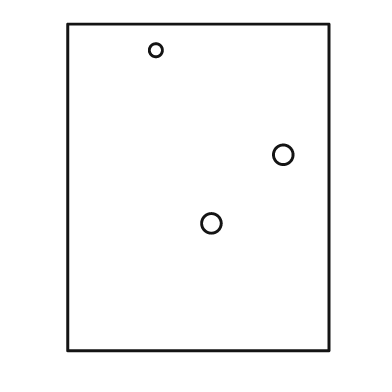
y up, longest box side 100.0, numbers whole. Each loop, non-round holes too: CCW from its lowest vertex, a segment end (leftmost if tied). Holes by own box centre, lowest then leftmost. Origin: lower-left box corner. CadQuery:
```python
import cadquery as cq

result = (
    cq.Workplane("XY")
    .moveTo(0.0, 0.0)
    .lineTo(80.0, 0.0)
    .lineTo(80.0, 100.0)
    .lineTo(0.0, 100.0)
    .close()
    .moveTo(44.0, 39.0)
    .circle(3.0)
    .moveTo(66.0, 60.0)
    .circle(3.0)
    .moveTo(27.0, 92.0)
    .circle(2.0)
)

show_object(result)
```